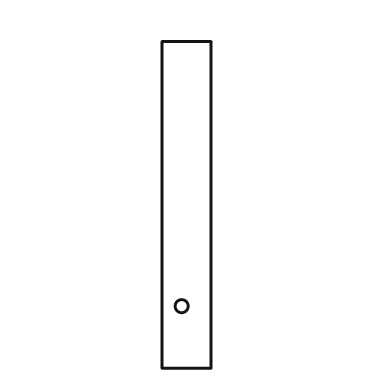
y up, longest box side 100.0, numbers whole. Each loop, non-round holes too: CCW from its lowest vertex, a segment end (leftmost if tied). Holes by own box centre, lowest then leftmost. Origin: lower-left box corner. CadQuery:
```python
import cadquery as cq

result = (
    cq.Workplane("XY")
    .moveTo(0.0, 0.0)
    .lineTo(15.0, 0.0)
    .lineTo(15.0, 100.0)
    .lineTo(0.0, 100.0)
    .close()
    .moveTo(6.0, 19.0)
    .circle(2.0)
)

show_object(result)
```